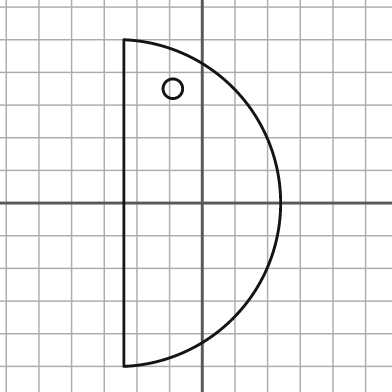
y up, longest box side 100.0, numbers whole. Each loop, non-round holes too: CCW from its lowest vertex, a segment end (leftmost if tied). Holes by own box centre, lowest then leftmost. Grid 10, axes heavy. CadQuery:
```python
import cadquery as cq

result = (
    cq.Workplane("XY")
    .moveTo(-24.0, -50.0)
    .threePointArc((24.0, 0.0), (-24.0, 50.0))
    .close()
    .moveTo(-9.0, 35.0)
    .circle(3.0)
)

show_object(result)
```